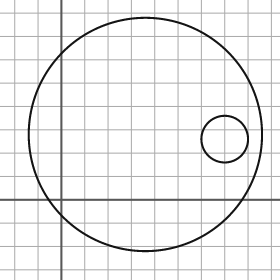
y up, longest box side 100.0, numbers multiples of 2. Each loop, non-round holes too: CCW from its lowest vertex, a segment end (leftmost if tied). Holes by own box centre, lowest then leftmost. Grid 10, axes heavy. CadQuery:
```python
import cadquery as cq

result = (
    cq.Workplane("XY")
    .moveTo(36.0, 28.0)
    .circle(50.0)
    .moveTo(70.0, 26.0)
    .circle(10.0)
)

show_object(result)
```